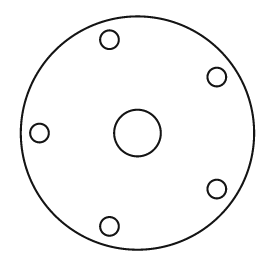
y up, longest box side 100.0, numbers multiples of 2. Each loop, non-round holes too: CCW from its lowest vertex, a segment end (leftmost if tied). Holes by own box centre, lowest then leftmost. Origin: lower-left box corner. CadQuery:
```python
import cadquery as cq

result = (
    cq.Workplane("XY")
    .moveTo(50.0, 50.0)
    .circle(50.0)
    .moveTo(38.0, 10.0)
    .circle(4.0)
    .moveTo(84.0, 26.0)
    .circle(4.0)
    .moveTo(8.0, 50.0)
    .circle(4.0)
    .moveTo(50.0, 50.0)
    .circle(10.0)
    .moveTo(84.0, 74.0)
    .circle(4.0)
    .moveTo(38.0, 90.0)
    .circle(4.0)
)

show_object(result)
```